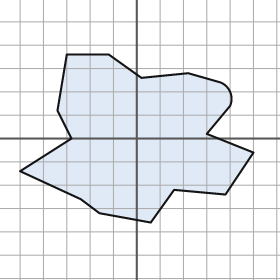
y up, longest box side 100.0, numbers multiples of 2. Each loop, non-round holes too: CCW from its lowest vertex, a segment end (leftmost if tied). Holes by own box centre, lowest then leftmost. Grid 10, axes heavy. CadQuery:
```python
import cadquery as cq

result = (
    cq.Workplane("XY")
    .moveTo(6.0, -36.0)
    .lineTo(16.0, -22.0)
    .lineTo(38.0, -24.0)
    .lineTo(50.0, -6.0)
    .lineTo(30.0, 2.0)
    .lineTo(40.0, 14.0)
    .threePointArc((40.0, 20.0), (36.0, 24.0))
    .lineTo(22.0, 28.0)
    .lineTo(2.0, 26.0)
    .lineTo(-12.0, 36.0)
    .lineTo(-30.0, 36.0)
    .lineTo(-34.0, 12.0)
    .lineTo(-28.0, 0.0)
    .lineTo(-50.0, -14.0)
    .lineTo(-24.0, -26.0)
    .lineTo(-16.0, -32.0)
    .close()
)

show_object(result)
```